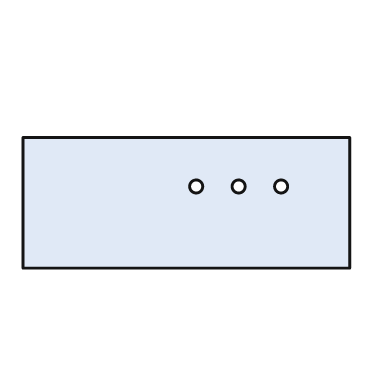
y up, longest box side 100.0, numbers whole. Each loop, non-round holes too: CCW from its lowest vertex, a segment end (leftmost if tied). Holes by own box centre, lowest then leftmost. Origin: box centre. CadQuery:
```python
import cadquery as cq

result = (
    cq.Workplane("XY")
    .moveTo(-50.0, -20.0)
    .lineTo(50.0, -20.0)
    .lineTo(50.0, 20.0)
    .lineTo(-50.0, 20.0)
    .close()
    .moveTo(3.0, 5.0)
    .circle(2.0)
    .moveTo(16.0, 5.0)
    .circle(2.0)
    .moveTo(29.0, 5.0)
    .circle(2.0)
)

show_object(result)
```